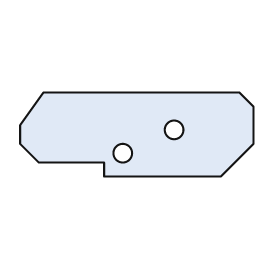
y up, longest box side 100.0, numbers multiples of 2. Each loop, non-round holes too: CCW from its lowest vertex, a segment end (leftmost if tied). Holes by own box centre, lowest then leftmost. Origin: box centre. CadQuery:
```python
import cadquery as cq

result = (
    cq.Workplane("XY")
    .moveTo(-14.0, -18.0)
    .lineTo(36.0, -18.0)
    .lineTo(50.0, -4.0)
    .lineTo(50.0, 12.0)
    .lineTo(44.0, 18.0)
    .lineTo(-40.0, 18.0)
    .lineTo(-50.0, 4.0)
    .lineTo(-50.0, -4.0)
    .lineTo(-42.0, -12.0)
    .lineTo(-14.0, -12.0)
    .close()
    .moveTo(-6.0, -8.0)
    .circle(4.0)
    .moveTo(16.0, 2.0)
    .circle(4.0)
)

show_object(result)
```